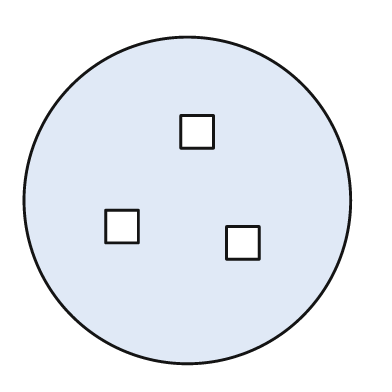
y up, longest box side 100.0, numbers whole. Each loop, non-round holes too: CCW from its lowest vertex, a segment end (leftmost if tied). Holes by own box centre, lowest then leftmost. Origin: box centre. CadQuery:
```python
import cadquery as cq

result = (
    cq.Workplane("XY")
    .moveTo(0.0, 0.0)
    .circle(50.0)
    .moveTo(12.0, -18.0)
    .lineTo(22.0, -18.0)
    .lineTo(22.0, -8.0)
    .lineTo(12.0, -8.0)
    .close()
    .moveTo(-25.0, -13.0)
    .lineTo(-15.0, -13.0)
    .lineTo(-15.0, -3.0)
    .lineTo(-25.0, -3.0)
    .close()
    .moveTo(-2.0, 16.0)
    .lineTo(8.0, 16.0)
    .lineTo(8.0, 26.0)
    .lineTo(-2.0, 26.0)
    .close()
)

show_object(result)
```